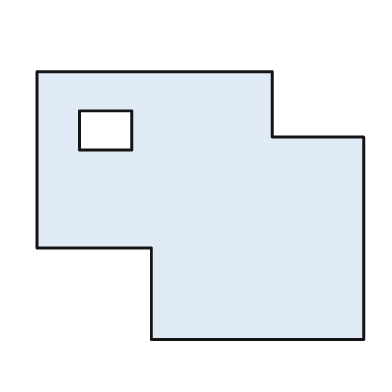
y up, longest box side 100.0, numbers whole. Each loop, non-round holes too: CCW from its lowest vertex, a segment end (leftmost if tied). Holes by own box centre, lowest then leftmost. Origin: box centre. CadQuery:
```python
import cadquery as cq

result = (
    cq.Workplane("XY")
    .moveTo(-15.0, -41.0)
    .lineTo(50.0, -41.0)
    .lineTo(50.0, 21.0)
    .lineTo(22.0, 21.0)
    .lineTo(22.0, 41.0)
    .lineTo(-50.0, 41.0)
    .lineTo(-50.0, -13.0)
    .lineTo(-15.0, -13.0)
    .close()
    .moveTo(-37.0, 17.0)
    .lineTo(-21.0, 17.0)
    .lineTo(-21.0, 29.0)
    .lineTo(-37.0, 29.0)
    .close()
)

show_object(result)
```